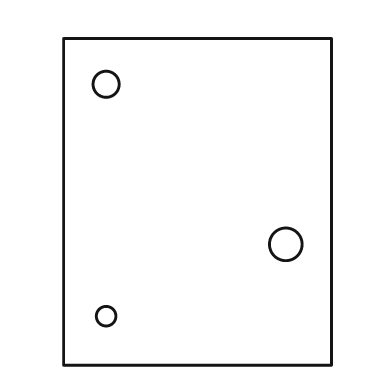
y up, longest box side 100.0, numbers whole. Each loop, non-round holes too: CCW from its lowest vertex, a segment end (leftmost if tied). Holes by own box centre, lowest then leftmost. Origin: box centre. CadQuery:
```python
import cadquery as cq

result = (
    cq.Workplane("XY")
    .moveTo(-41.0, -50.0)
    .lineTo(41.0, -50.0)
    .lineTo(41.0, 50.0)
    .lineTo(-41.0, 50.0)
    .close()
    .moveTo(-28.0, -35.0)
    .circle(3.0)
    .moveTo(27.0, -13.0)
    .circle(5.0)
    .moveTo(-28.0, 36.0)
    .circle(4.0)
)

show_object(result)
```